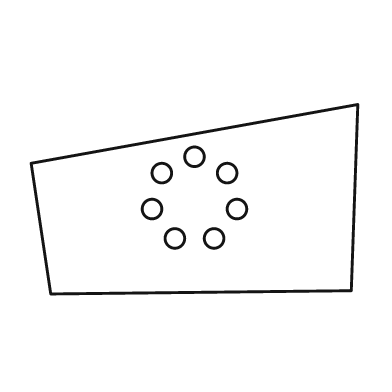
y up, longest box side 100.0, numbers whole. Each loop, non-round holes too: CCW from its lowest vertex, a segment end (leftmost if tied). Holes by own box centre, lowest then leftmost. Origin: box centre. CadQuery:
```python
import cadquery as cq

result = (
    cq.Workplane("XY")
    .moveTo(-44.0, -29.0)
    .lineTo(48.0, -28.0)
    .lineTo(50.0, 29.0)
    .lineTo(-50.0, 11.0)
    .close()
    .moveTo(-6.0, -12.0)
    .circle(3.0)
    .moveTo(6.0, -12.0)
    .circle(3.0)
    .moveTo(-13.0, -3.0)
    .circle(3.0)
    .moveTo(13.0, -3.0)
    .circle(3.0)
    .moveTo(-10.0, 8.0)
    .circle(3.0)
    .moveTo(10.0, 8.0)
    .circle(3.0)
    .moveTo(0.0, 13.0)
    .circle(3.0)
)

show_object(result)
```